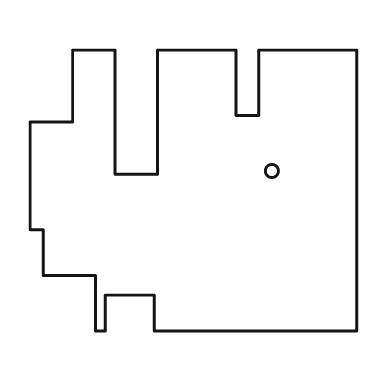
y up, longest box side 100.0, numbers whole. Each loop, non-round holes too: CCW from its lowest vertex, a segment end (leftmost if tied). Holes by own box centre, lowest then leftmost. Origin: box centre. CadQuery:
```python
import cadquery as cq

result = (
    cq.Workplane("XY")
    .moveTo(-30.0, -43.0)
    .lineTo(-27.0, -43.0)
    .lineTo(-27.0, -32.0)
    .lineTo(-12.0, -32.0)
    .lineTo(-12.0, -43.0)
    .lineTo(50.0, -43.0)
    .lineTo(50.0, 43.0)
    .lineTo(20.0, 43.0)
    .lineTo(20.0, 23.0)
    .lineTo(13.0, 23.0)
    .lineTo(13.0, 43.0)
    .lineTo(-11.0, 43.0)
    .lineTo(-11.0, 5.0)
    .lineTo(-24.0, 5.0)
    .lineTo(-24.0, 43.0)
    .lineTo(-37.0, 43.0)
    .lineTo(-37.0, 21.0)
    .lineTo(-50.0, 21.0)
    .lineTo(-50.0, -12.0)
    .lineTo(-46.0, -12.0)
    .lineTo(-46.0, -26.0)
    .lineTo(-30.0, -26.0)
    .close()
    .moveTo(24.0, 6.0)
    .circle(2.0)
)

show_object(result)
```